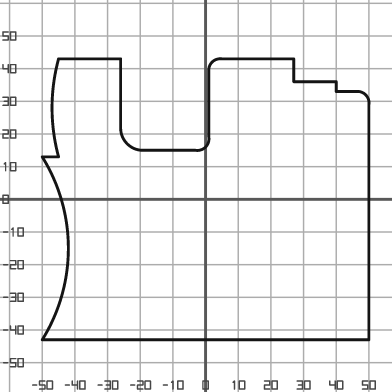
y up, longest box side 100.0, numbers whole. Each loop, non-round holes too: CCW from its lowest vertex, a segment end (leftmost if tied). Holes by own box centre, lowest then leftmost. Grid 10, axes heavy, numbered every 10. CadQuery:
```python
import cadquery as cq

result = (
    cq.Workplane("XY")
    .moveTo(-50.0, -43.0)
    .lineTo(50.0, -43.0)
    .lineTo(50.0, 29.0)
    .threePointArc((49.0, 32.0), (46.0, 33.0))
    .lineTo(40.0, 33.0)
    .lineTo(40.0, 36.0)
    .lineTo(27.0, 36.0)
    .lineTo(27.0, 43.0)
    .lineTo(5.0, 43.0)
    .threePointArc((2.0, 42.0), (1.0, 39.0))
    .lineTo(1.0, 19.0)
    .threePointArc((0.0, 16.0), (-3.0, 15.0))
    .lineTo(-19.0, 15.0)
    .threePointArc((-24.0, 17.0), (-26.0, 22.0))
    .lineTo(-26.0, 43.0)
    .lineTo(-45.0, 43.0)
    .threePointArc((-47.0, 28.0), (-45.0, 13.0))
    .lineTo(-50.0, 13.0)
    .threePointArc((-42.0, -15.0), (-50.0, -43.0))
    .close()
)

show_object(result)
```